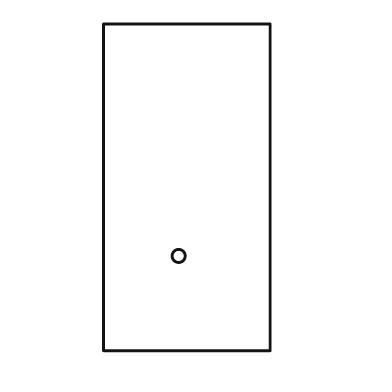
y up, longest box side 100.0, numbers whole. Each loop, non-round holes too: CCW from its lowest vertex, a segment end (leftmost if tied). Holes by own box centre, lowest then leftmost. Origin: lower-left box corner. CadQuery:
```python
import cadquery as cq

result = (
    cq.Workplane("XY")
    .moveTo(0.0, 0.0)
    .lineTo(51.0, 0.0)
    .lineTo(51.0, 100.0)
    .lineTo(0.0, 100.0)
    .close()
    .moveTo(23.0, 29.0)
    .circle(2.0)
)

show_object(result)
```